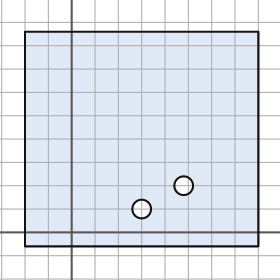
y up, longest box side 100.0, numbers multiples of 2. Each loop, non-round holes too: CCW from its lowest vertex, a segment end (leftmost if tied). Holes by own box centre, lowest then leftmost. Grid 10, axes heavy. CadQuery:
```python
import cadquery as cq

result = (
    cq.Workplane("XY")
    .moveTo(-20.0, -6.0)
    .lineTo(80.0, -6.0)
    .lineTo(80.0, 86.0)
    .lineTo(-20.0, 86.0)
    .close()
    .moveTo(30.0, 10.0)
    .circle(4.0)
    .moveTo(48.0, 20.0)
    .circle(4.0)
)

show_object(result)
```